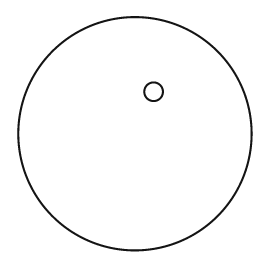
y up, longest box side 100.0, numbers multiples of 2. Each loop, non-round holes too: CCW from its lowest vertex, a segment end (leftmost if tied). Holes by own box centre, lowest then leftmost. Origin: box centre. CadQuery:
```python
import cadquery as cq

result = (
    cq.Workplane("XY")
    .moveTo(0.0, 0.0)
    .circle(50.0)
    .moveTo(8.0, 18.0)
    .circle(4.0)
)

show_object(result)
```